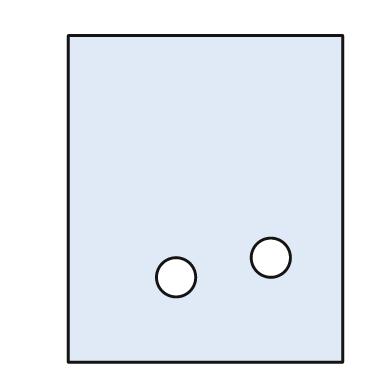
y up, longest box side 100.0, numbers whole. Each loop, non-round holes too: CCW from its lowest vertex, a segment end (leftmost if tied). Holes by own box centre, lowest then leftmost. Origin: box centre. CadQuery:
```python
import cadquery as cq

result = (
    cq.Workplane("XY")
    .moveTo(-42.0, -50.0)
    .lineTo(42.0, -50.0)
    .lineTo(42.0, 50.0)
    .lineTo(-42.0, 50.0)
    .close()
    .moveTo(-9.0, -24.0)
    .circle(6.0)
    .moveTo(20.0, -18.0)
    .circle(6.0)
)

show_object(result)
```